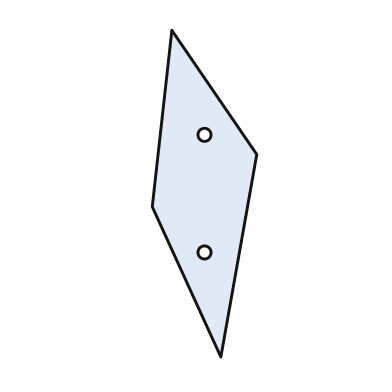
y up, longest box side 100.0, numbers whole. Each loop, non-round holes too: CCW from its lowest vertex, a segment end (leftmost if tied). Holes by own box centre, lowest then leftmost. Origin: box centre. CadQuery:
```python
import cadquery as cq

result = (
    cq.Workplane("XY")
    .moveTo(5.0, -50.0)
    .lineTo(16.0, 12.0)
    .lineTo(-10.0, 50.0)
    .lineTo(-16.0, -4.0)
    .close()
    .moveTo(0.0, -18.0)
    .circle(2.0)
    .moveTo(0.0, 18.0)
    .circle(2.0)
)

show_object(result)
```